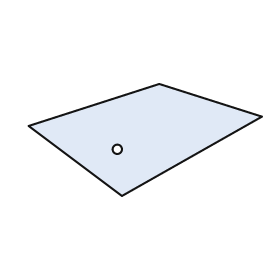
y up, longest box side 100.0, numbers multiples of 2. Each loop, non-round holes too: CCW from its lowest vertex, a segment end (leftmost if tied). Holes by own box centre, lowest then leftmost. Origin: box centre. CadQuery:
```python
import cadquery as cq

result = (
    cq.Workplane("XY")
    .moveTo(-10.0, -24.0)
    .lineTo(50.0, 10.0)
    .lineTo(6.0, 24.0)
    .lineTo(-50.0, 6.0)
    .close()
    .moveTo(-12.0, -4.0)
    .circle(2.0)
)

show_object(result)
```